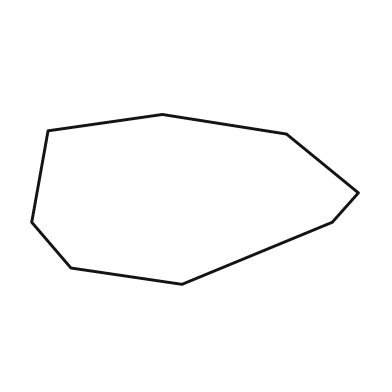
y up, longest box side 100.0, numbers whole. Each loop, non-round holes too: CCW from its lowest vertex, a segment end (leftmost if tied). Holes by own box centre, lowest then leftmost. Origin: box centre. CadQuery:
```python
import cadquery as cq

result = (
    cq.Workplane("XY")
    .moveTo(-4.0, -26.0)
    .lineTo(42.0, -7.0)
    .lineTo(50.0, 2.0)
    .lineTo(28.0, 20.0)
    .lineTo(-10.0, 26.0)
    .lineTo(-45.0, 21.0)
    .lineTo(-50.0, -7.0)
    .lineTo(-38.0, -21.0)
    .close()
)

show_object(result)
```